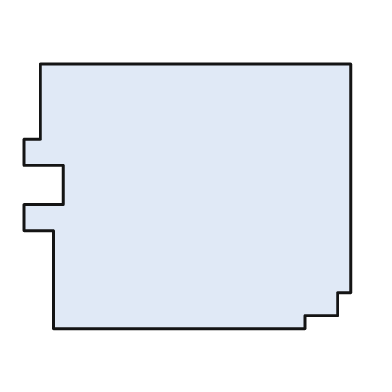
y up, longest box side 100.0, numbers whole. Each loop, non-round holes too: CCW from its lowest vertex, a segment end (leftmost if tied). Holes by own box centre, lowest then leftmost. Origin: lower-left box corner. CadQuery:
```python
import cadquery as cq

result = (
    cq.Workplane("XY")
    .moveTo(9.0, 0.0)
    .lineTo(86.0, 0.0)
    .lineTo(86.0, 4.0)
    .lineTo(96.0, 4.0)
    .lineTo(96.0, 11.0)
    .lineTo(100.0, 11.0)
    .lineTo(100.0, 81.0)
    .lineTo(5.0, 81.0)
    .lineTo(5.0, 58.0)
    .lineTo(0.0, 58.0)
    .lineTo(0.0, 50.0)
    .lineTo(12.0, 50.0)
    .lineTo(12.0, 38.0)
    .lineTo(0.0, 38.0)
    .lineTo(0.0, 30.0)
    .lineTo(9.0, 30.0)
    .close()
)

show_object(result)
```